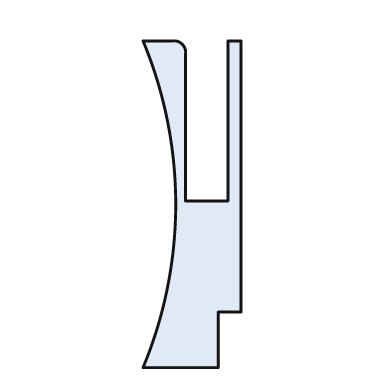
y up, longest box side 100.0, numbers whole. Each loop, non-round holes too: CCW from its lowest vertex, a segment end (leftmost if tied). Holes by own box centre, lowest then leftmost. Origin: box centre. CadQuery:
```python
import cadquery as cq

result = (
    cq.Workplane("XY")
    .moveTo(-15.0, -50.0)
    .lineTo(8.0, -50.0)
    .lineTo(8.0, -33.0)
    .lineTo(15.0, -33.0)
    .lineTo(15.0, 50.0)
    .lineTo(11.0, 50.0)
    .lineTo(11.0, 1.0)
    .lineTo(-2.0, 1.0)
    .lineTo(-2.0, 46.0)
    .threePointArc((-3.0, 49.0), (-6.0, 50.0))
    .lineTo(-15.0, 50.0)
    .threePointArc((-5.0, 0.0), (-15.0, -50.0))
    .close()
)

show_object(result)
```